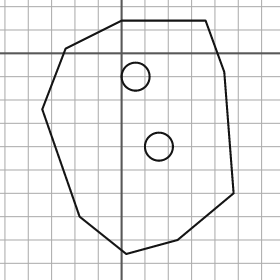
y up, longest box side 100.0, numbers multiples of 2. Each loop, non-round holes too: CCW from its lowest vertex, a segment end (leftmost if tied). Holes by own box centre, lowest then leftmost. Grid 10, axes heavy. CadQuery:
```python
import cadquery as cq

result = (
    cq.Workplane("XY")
    .moveTo(2.0, -86.0)
    .lineTo(24.0, -80.0)
    .lineTo(48.0, -60.0)
    .lineTo(44.0, -8.0)
    .lineTo(36.0, 14.0)
    .lineTo(0.0, 14.0)
    .lineTo(-24.0, 2.0)
    .lineTo(-34.0, -24.0)
    .lineTo(-18.0, -70.0)
    .close()
    .moveTo(16.0, -40.0)
    .circle(6.0)
    .moveTo(6.0, -10.0)
    .circle(6.0)
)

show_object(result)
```